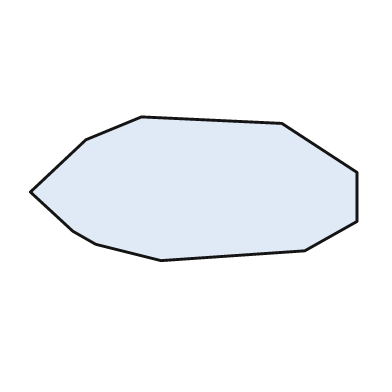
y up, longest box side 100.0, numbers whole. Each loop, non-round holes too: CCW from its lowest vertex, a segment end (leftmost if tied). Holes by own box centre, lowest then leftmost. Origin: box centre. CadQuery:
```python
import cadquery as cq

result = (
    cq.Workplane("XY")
    .moveTo(-10.0, -22.0)
    .lineTo(34.0, -19.0)
    .lineTo(50.0, -10.0)
    .lineTo(50.0, 5.0)
    .lineTo(27.0, 20.0)
    .lineTo(-16.0, 22.0)
    .lineTo(-33.0, 15.0)
    .lineTo(-50.0, -1.0)
    .lineTo(-37.0, -13.0)
    .lineTo(-30.0, -17.0)
    .close()
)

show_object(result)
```